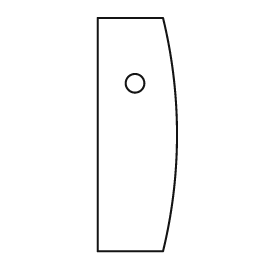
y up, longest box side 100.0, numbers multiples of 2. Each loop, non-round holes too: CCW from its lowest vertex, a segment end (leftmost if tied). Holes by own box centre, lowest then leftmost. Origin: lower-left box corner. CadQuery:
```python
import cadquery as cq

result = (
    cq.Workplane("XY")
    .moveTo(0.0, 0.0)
    .lineTo(28.0, 0.0)
    .threePointArc((34.0, 50.0), (28.0, 100.0))
    .lineTo(0.0, 100.0)
    .close()
    .moveTo(16.0, 72.0)
    .circle(4.0)
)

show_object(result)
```